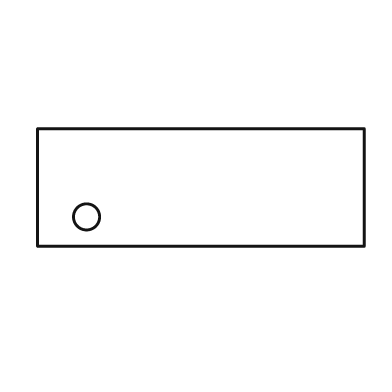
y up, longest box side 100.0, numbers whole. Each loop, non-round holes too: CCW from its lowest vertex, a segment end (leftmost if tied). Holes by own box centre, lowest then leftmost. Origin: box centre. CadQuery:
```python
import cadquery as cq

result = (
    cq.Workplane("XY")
    .moveTo(-50.0, -18.0)
    .lineTo(50.0, -18.0)
    .lineTo(50.0, 18.0)
    .lineTo(-50.0, 18.0)
    .close()
    .moveTo(-35.0, -9.0)
    .circle(4.0)
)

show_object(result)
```